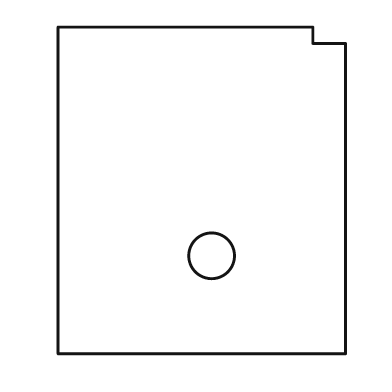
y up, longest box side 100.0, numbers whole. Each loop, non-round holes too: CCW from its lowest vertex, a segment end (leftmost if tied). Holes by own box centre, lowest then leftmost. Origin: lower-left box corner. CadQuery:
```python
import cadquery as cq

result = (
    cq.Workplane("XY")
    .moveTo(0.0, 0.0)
    .lineTo(88.0, 0.0)
    .lineTo(88.0, 95.0)
    .lineTo(78.0, 95.0)
    .lineTo(78.0, 100.0)
    .lineTo(0.0, 100.0)
    .close()
    .moveTo(47.0, 30.0)
    .circle(7.0)
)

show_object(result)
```